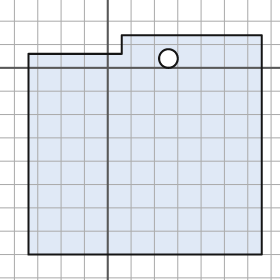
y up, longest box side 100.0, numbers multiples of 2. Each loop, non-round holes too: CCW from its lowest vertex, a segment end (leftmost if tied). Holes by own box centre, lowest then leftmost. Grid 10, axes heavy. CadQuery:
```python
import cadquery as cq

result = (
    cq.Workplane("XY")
    .moveTo(-34.0, -80.0)
    .lineTo(66.0, -80.0)
    .lineTo(66.0, 14.0)
    .lineTo(6.0, 14.0)
    .lineTo(6.0, 6.0)
    .lineTo(-34.0, 6.0)
    .close()
    .moveTo(26.0, 4.0)
    .circle(4.0)
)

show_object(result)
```